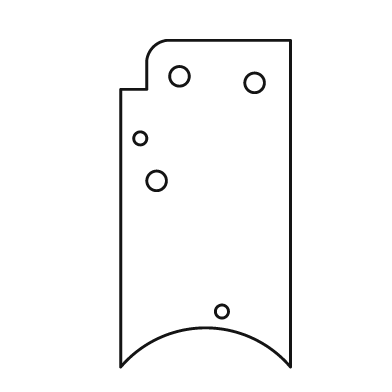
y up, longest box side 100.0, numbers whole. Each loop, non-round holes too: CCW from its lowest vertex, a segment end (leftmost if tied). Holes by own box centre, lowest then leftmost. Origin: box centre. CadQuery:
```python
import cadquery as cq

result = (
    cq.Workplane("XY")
    .moveTo(-26.0, -50.0)
    .threePointArc((0.0, -38.0), (26.0, -50.0))
    .lineTo(26.0, 50.0)
    .lineTo(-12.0, 50.0)
    .threePointArc((-16.0, 48.0), (-18.0, 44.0))
    .lineTo(-18.0, 35.0)
    .lineTo(-26.0, 35.0)
    .close()
    .moveTo(5.0, -33.0)
    .circle(2.0)
    .moveTo(-15.0, 7.0)
    .circle(3.0)
    .moveTo(-20.0, 20.0)
    .circle(2.0)
    .moveTo(15.0, 37.0)
    .circle(3.0)
    .moveTo(-8.0, 39.0)
    .circle(3.0)
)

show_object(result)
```